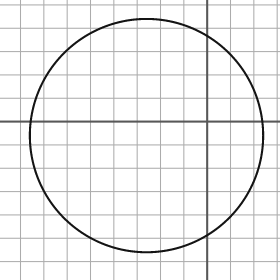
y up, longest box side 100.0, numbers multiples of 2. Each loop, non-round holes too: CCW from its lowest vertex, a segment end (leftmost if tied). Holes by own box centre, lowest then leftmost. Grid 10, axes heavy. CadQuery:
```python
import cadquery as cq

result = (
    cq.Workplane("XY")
    .moveTo(-26.0, -6.0)
    .circle(50.0)
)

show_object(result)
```